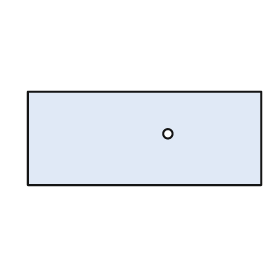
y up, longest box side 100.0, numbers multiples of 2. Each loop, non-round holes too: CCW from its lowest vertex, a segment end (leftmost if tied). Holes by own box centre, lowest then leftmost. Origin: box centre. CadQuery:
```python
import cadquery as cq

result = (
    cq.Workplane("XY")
    .moveTo(-50.0, -20.0)
    .lineTo(50.0, -20.0)
    .lineTo(50.0, 20.0)
    .lineTo(-50.0, 20.0)
    .close()
    .moveTo(10.0, 2.0)
    .circle(2.0)
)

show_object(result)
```